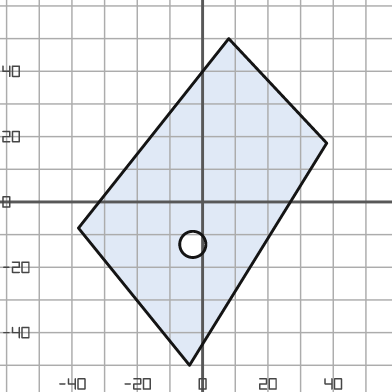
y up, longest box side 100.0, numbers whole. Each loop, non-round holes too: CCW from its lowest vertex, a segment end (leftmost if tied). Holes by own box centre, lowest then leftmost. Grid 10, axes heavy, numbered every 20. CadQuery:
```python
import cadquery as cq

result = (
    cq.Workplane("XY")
    .moveTo(-4.0, -50.0)
    .lineTo(38.0, 18.0)
    .lineTo(8.0, 50.0)
    .lineTo(-38.0, -8.0)
    .close()
    .moveTo(-3.0, -13.0)
    .circle(4.0)
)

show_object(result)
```